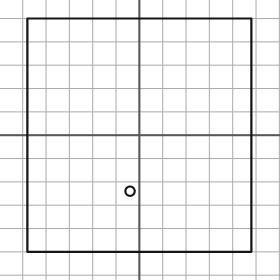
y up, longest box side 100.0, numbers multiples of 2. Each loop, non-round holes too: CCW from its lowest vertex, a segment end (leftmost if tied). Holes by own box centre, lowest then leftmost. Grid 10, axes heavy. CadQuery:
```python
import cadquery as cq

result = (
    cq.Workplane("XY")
    .moveTo(-48.0, -50.0)
    .lineTo(48.0, -50.0)
    .lineTo(48.0, 50.0)
    .lineTo(-48.0, 50.0)
    .close()
    .moveTo(-4.0, -24.0)
    .circle(2.0)
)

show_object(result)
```